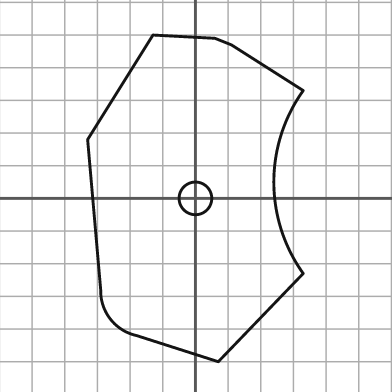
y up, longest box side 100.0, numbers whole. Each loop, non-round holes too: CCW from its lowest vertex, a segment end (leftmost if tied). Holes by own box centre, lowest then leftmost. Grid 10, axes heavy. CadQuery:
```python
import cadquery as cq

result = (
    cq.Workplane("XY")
    .moveTo(7.0, -50.0)
    .lineTo(33.0, -23.0)
    .threePointArc((24.0, 5.0), (33.0, 33.0))
    .lineTo(11.0, 47.0)
    .lineTo(6.0, 49.0)
    .lineTo(-13.0, 50.0)
    .lineTo(-33.0, 18.0)
    .lineTo(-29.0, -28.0)
    .threePointArc((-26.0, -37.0), (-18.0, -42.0))
    .close()
    .moveTo(0.0, 0.0)
    .circle(5.0)
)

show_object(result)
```